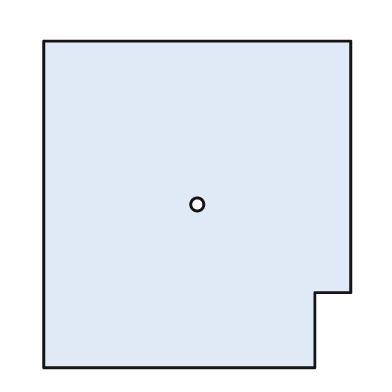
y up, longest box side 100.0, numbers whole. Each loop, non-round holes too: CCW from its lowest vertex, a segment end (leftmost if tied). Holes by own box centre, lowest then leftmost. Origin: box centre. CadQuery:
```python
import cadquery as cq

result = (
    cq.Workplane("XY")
    .moveTo(-47.0, -50.0)
    .lineTo(36.0, -50.0)
    .lineTo(36.0, -27.0)
    .lineTo(47.0, -27.0)
    .lineTo(47.0, 50.0)
    .lineTo(-47.0, 50.0)
    .close()
    .moveTo(0.0, 0.0)
    .circle(2.0)
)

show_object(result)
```